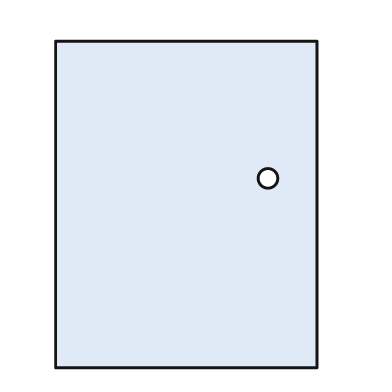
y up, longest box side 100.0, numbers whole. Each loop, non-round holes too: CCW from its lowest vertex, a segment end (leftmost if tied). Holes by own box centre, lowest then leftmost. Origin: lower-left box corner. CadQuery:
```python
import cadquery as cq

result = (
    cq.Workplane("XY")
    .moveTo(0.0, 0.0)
    .lineTo(80.0, 0.0)
    .lineTo(80.0, 100.0)
    .lineTo(0.0, 100.0)
    .close()
    .moveTo(65.0, 58.0)
    .circle(3.0)
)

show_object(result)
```